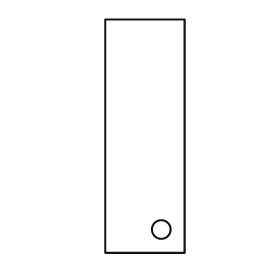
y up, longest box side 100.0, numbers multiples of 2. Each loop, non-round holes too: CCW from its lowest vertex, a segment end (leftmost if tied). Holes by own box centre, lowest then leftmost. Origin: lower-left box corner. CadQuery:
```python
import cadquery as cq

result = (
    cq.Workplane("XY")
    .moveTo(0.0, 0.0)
    .lineTo(34.0, 0.0)
    .lineTo(34.0, 100.0)
    .lineTo(0.0, 100.0)
    .close()
    .moveTo(24.0, 10.0)
    .circle(4.0)
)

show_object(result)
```